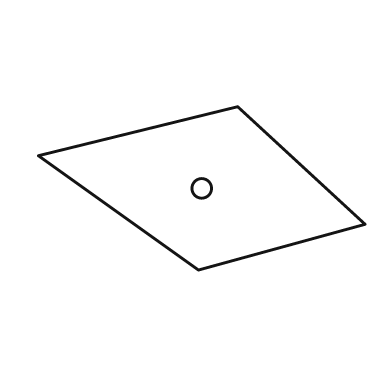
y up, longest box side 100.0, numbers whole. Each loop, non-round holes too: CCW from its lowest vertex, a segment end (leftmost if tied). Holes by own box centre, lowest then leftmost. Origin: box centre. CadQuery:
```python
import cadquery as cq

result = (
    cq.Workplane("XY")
    .moveTo(-1.0, -25.0)
    .lineTo(50.0, -11.0)
    .lineTo(11.0, 25.0)
    .lineTo(-50.0, 10.0)
    .close()
    .moveTo(0.0, 0.0)
    .circle(3.0)
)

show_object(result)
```